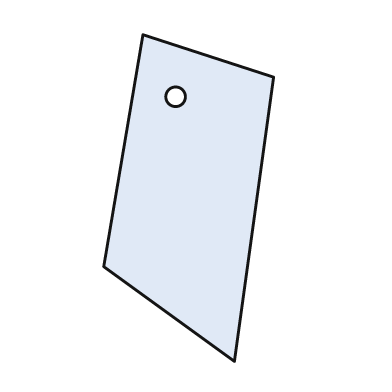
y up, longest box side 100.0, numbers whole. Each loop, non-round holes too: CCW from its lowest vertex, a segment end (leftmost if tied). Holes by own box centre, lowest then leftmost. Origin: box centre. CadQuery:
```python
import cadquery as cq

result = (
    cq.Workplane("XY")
    .moveTo(14.0, -50.0)
    .lineTo(26.0, 37.0)
    .lineTo(-14.0, 50.0)
    .lineTo(-26.0, -21.0)
    .close()
    .moveTo(-4.0, 31.0)
    .circle(3.0)
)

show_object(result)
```